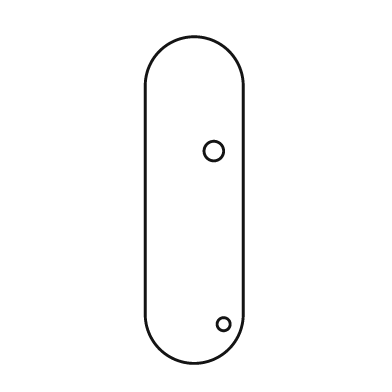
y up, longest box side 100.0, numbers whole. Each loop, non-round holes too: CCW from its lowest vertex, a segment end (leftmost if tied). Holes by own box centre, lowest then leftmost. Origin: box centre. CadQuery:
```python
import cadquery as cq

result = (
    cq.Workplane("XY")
    .moveTo(-15.0, -35.0)
    .threePointArc((0.0, -50.0), (15.0, -35.0))
    .lineTo(15.0, 35.0)
    .threePointArc((0.0, 50.0), (-15.0, 35.0))
    .close()
    .moveTo(9.0, -38.0)
    .circle(2.0)
    .moveTo(6.0, 15.0)
    .circle(3.0)
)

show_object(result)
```